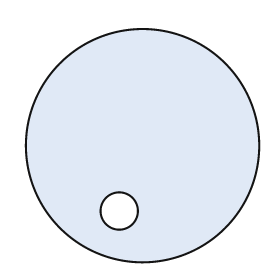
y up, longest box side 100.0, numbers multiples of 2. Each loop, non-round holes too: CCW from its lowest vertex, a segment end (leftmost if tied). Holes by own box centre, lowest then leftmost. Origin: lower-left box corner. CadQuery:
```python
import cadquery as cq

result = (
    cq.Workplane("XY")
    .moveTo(50.0, 50.0)
    .circle(50.0)
    .moveTo(40.0, 22.0)
    .circle(8.0)
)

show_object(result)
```